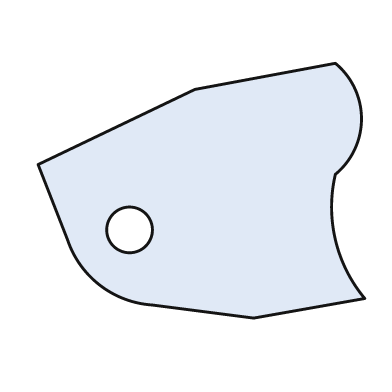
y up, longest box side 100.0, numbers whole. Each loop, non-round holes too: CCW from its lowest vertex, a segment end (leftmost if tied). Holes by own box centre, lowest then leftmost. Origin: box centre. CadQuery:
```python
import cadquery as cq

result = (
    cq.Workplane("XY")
    .moveTo(16.0, -39.0)
    .lineTo(50.0, -33.0)
    .threePointArc((41.0, -15.0), (41.0, 5.0))
    .threePointArc((49.0, 22.0), (41.0, 39.0))
    .lineTo(-2.0, 31.0)
    .lineTo(-50.0, 8.0)
    .lineTo(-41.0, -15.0)
    .threePointArc((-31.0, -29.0), (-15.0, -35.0))
    .close()
    .moveTo(-22.0, -12.0)
    .circle(7.0)
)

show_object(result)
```